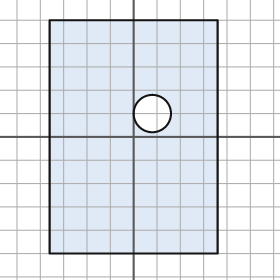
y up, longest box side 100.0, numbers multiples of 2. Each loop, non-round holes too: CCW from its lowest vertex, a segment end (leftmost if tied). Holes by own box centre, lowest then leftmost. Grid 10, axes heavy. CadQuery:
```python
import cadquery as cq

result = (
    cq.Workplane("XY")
    .moveTo(-36.0, -50.0)
    .lineTo(36.0, -50.0)
    .lineTo(36.0, 50.0)
    .lineTo(-36.0, 50.0)
    .close()
    .moveTo(8.0, 10.0)
    .circle(8.0)
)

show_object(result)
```